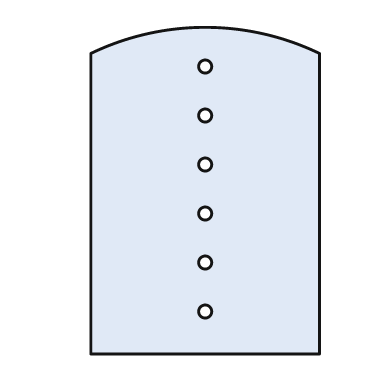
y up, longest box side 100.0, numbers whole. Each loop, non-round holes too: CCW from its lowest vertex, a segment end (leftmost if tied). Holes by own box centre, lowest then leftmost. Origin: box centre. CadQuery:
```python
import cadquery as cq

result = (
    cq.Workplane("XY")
    .moveTo(-35.0, -50.0)
    .lineTo(35.0, -50.0)
    .lineTo(35.0, 42.0)
    .threePointArc((0.0, 50.0), (-35.0, 42.0))
    .close()
    .moveTo(0.0, -37.0)
    .circle(2.0)
    .moveTo(0.0, -22.0)
    .circle(2.0)
    .moveTo(0.0, -7.0)
    .circle(2.0)
    .moveTo(0.0, 8.0)
    .circle(2.0)
    .moveTo(0.0, 23.0)
    .circle(2.0)
    .moveTo(0.0, 38.0)
    .circle(2.0)
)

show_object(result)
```